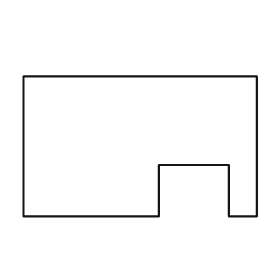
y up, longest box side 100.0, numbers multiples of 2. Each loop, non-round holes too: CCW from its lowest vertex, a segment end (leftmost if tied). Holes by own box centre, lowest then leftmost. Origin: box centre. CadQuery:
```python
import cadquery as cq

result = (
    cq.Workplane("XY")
    .moveTo(-50.0, -30.0)
    .lineTo(8.0, -30.0)
    .lineTo(8.0, -8.0)
    .lineTo(38.0, -8.0)
    .lineTo(38.0, -30.0)
    .lineTo(50.0, -30.0)
    .lineTo(50.0, 30.0)
    .lineTo(-50.0, 30.0)
    .close()
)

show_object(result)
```